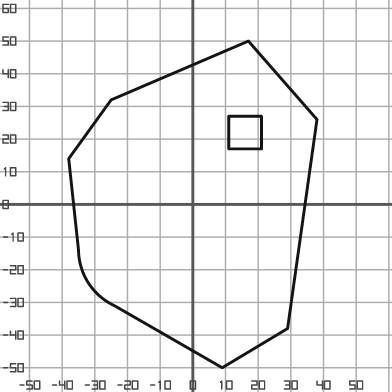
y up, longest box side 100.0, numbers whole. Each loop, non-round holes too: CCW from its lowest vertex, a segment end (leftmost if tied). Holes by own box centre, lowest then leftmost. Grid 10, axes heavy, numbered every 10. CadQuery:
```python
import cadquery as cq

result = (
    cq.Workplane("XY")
    .moveTo(9.0, -50.0)
    .lineTo(29.0, -38.0)
    .lineTo(38.0, 26.0)
    .lineTo(17.0, 50.0)
    .lineTo(-25.0, 32.0)
    .lineTo(-38.0, 14.0)
    .lineTo(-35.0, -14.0)
    .threePointArc((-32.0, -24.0), (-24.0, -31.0))
    .close()
    .moveTo(11.0, 17.0)
    .lineTo(21.0, 17.0)
    .lineTo(21.0, 27.0)
    .lineTo(11.0, 27.0)
    .close()
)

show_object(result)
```